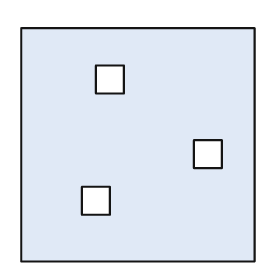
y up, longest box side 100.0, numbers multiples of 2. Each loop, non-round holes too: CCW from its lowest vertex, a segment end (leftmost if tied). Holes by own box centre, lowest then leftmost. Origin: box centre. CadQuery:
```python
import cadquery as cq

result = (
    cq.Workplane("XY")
    .moveTo(-50.0, -50.0)
    .lineTo(50.0, -50.0)
    .lineTo(50.0, 50.0)
    .lineTo(-50.0, 50.0)
    .close()
    .moveTo(-24.0, -30.0)
    .lineTo(-12.0, -30.0)
    .lineTo(-12.0, -18.0)
    .lineTo(-24.0, -18.0)
    .close()
    .moveTo(24.0, -10.0)
    .lineTo(36.0, -10.0)
    .lineTo(36.0, 2.0)
    .lineTo(24.0, 2.0)
    .close()
    .moveTo(-18.0, 22.0)
    .lineTo(-6.0, 22.0)
    .lineTo(-6.0, 34.0)
    .lineTo(-18.0, 34.0)
    .close()
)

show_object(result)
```